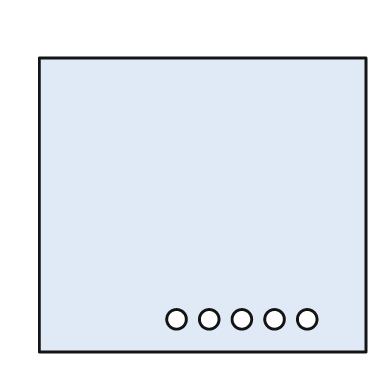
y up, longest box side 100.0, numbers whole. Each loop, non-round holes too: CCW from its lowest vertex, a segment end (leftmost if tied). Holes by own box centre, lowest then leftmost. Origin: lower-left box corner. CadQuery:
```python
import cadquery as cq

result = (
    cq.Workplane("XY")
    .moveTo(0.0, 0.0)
    .lineTo(100.0, 0.0)
    .lineTo(100.0, 90.0)
    .lineTo(0.0, 90.0)
    .close()
    .moveTo(42.0, 10.0)
    .circle(3.0)
    .moveTo(52.0, 10.0)
    .circle(3.0)
    .moveTo(62.0, 10.0)
    .circle(3.0)
    .moveTo(72.0, 10.0)
    .circle(3.0)
    .moveTo(82.0, 10.0)
    .circle(3.0)
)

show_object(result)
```